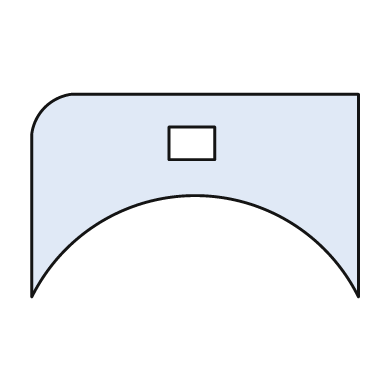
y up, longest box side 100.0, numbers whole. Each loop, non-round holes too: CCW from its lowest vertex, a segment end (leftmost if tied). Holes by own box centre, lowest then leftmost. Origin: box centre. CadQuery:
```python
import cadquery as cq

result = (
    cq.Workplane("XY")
    .moveTo(-50.0, -31.0)
    .threePointArc((0.0, 0.0), (50.0, -31.0))
    .lineTo(50.0, 31.0)
    .lineTo(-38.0, 31.0)
    .threePointArc((-46.0, 27.0), (-50.0, 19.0))
    .close()
    .moveTo(-8.0, 11.0)
    .lineTo(6.0, 11.0)
    .lineTo(6.0, 21.0)
    .lineTo(-8.0, 21.0)
    .close()
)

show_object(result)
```